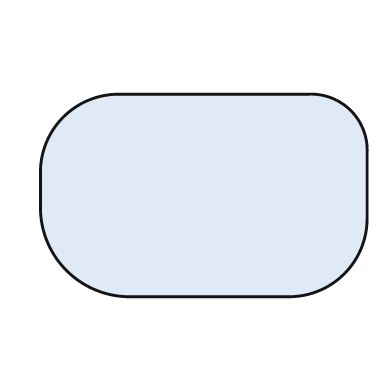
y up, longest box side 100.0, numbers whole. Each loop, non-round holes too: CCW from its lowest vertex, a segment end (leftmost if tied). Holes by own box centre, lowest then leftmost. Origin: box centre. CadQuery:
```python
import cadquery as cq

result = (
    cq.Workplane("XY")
    .moveTo(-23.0, -31.0)
    .lineTo(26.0, -31.0)
    .threePointArc((43.0, -24.0), (50.0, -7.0))
    .lineTo(50.0, 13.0)
    .threePointArc((45.0, 26.0), (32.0, 31.0))
    .lineTo(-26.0, 31.0)
    .threePointArc((-43.0, 24.0), (-50.0, 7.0))
    .lineTo(-50.0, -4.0)
    .threePointArc((-42.0, -23.0), (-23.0, -31.0))
    .close()
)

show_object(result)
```